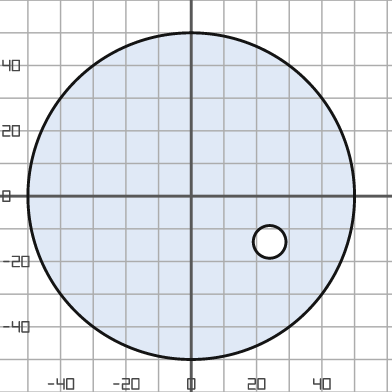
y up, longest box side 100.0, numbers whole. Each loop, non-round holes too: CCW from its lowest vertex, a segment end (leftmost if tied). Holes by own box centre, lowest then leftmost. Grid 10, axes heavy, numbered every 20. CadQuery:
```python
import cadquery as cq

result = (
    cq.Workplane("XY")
    .moveTo(0.0, 0.0)
    .circle(50.0)
    .moveTo(24.0, -14.0)
    .circle(5.0)
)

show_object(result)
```